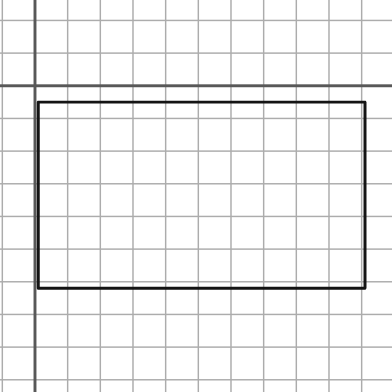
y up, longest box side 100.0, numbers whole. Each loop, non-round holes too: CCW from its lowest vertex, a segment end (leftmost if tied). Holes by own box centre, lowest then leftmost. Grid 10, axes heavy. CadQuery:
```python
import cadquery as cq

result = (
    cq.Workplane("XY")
    .moveTo(1.0, -62.0)
    .lineTo(101.0, -62.0)
    .lineTo(101.0, -5.0)
    .lineTo(1.0, -5.0)
    .close()
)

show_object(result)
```